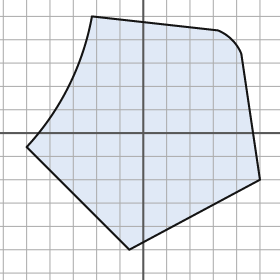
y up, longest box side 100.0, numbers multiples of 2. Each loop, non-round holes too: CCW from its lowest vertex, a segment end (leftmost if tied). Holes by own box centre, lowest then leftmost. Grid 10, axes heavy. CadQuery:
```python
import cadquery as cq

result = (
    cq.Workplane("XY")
    .moveTo(-6.0, -50.0)
    .lineTo(50.0, -20.0)
    .lineTo(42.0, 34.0)
    .threePointArc((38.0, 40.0), (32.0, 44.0))
    .lineTo(-22.0, 50.0)
    .threePointArc((-32.0, 20.0), (-50.0, -6.0))
    .close()
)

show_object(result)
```